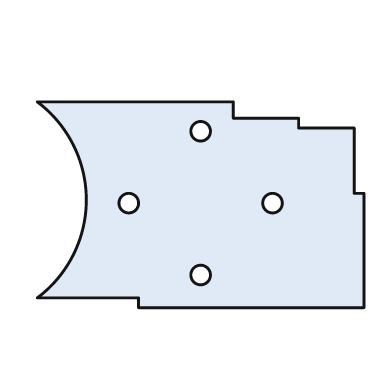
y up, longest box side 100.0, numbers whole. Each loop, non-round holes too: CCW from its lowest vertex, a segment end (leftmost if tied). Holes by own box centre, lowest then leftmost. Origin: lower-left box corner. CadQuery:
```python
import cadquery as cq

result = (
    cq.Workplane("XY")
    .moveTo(31.0, 0.0)
    .lineTo(100.0, 0.0)
    .lineTo(100.0, 35.0)
    .lineTo(97.0, 35.0)
    .lineTo(97.0, 55.0)
    .lineTo(80.0, 55.0)
    .lineTo(80.0, 58.0)
    .lineTo(60.0, 58.0)
    .lineTo(60.0, 63.0)
    .lineTo(0.0, 63.0)
    .threePointArc((15.0, 33.0), (0.0, 3.0))
    .lineTo(31.0, 3.0)
    .close()
    .moveTo(50.0, 10.0)
    .circle(3.0)
    .moveTo(28.0, 32.0)
    .circle(3.0)
    .moveTo(72.0, 32.0)
    .circle(3.0)
    .moveTo(50.0, 54.0)
    .circle(3.0)
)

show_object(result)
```